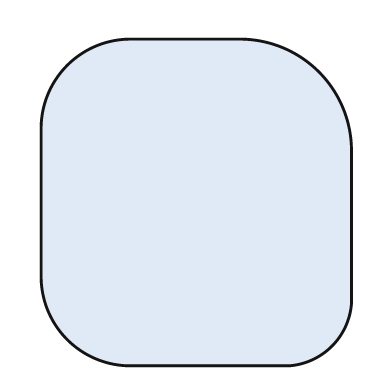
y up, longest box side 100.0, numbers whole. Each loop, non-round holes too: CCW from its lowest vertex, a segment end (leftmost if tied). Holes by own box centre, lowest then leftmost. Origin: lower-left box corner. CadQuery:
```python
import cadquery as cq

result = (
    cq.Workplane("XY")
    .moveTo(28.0, 0.0)
    .lineTo(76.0, 0.0)
    .threePointArc((89.0, 6.0), (95.0, 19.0))
    .lineTo(95.0, 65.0)
    .threePointArc((85.0, 90.0), (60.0, 100.0))
    .lineTo(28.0, 100.0)
    .threePointArc((8.0, 92.0), (0.0, 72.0))
    .lineTo(0.0, 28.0)
    .threePointArc((8.0, 8.0), (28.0, 0.0))
    .close()
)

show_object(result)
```